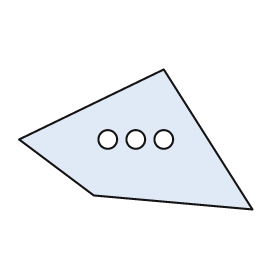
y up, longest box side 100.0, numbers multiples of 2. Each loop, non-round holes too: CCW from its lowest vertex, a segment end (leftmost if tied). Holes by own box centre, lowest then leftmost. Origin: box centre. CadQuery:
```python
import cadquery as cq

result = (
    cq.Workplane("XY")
    .moveTo(50.0, -30.0)
    .lineTo(12.0, 30.0)
    .lineTo(-50.0, 0.0)
    .lineTo(-18.0, -24.0)
    .close()
    .moveTo(-12.0, 0.0)
    .circle(4.0)
    .moveTo(0.0, 0.0)
    .circle(4.0)
    .moveTo(12.0, 0.0)
    .circle(4.0)
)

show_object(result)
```